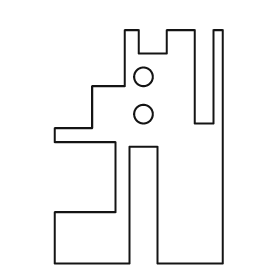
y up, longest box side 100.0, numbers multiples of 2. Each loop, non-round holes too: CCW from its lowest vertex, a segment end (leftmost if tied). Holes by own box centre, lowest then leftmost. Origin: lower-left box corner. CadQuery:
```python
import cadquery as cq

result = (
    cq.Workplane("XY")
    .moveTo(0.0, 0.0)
    .lineTo(32.0, 0.0)
    .lineTo(32.0, 50.0)
    .lineTo(44.0, 50.0)
    .lineTo(44.0, 0.0)
    .lineTo(72.0, 0.0)
    .lineTo(72.0, 100.0)
    .lineTo(68.0, 100.0)
    .lineTo(68.0, 60.0)
    .lineTo(60.0, 60.0)
    .lineTo(60.0, 100.0)
    .lineTo(48.0, 100.0)
    .lineTo(48.0, 90.0)
    .lineTo(36.0, 90.0)
    .lineTo(36.0, 100.0)
    .lineTo(30.0, 100.0)
    .lineTo(30.0, 76.0)
    .lineTo(16.0, 76.0)
    .lineTo(16.0, 58.0)
    .lineTo(0.0, 58.0)
    .lineTo(0.0, 52.0)
    .lineTo(26.0, 52.0)
    .lineTo(26.0, 22.0)
    .lineTo(0.0, 22.0)
    .close()
    .moveTo(38.0, 64.0)
    .circle(4.0)
    .moveTo(38.0, 80.0)
    .circle(4.0)
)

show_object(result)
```